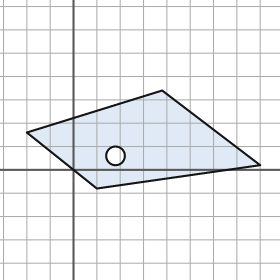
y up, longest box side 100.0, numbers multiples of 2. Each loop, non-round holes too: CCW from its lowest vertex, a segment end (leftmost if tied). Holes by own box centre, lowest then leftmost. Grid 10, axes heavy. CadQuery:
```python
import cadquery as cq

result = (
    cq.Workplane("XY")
    .moveTo(10.0, -8.0)
    .lineTo(80.0, 2.0)
    .lineTo(38.0, 34.0)
    .lineTo(-20.0, 16.0)
    .close()
    .moveTo(18.0, 6.0)
    .circle(4.0)
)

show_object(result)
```